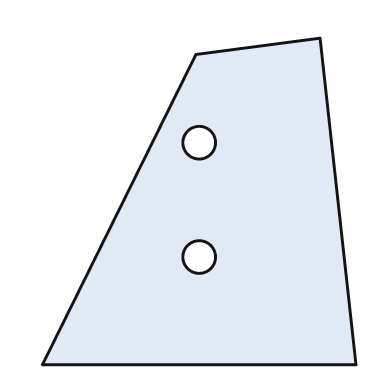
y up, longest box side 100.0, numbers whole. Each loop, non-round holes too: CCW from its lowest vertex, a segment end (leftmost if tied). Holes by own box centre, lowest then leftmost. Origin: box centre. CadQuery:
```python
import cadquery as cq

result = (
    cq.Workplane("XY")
    .moveTo(-48.0, -50.0)
    .lineTo(48.0, -50.0)
    .lineTo(37.0, 50.0)
    .lineTo(-1.0, 45.0)
    .close()
    .moveTo(0.0, -17.0)
    .circle(5.0)
    .moveTo(0.0, 18.0)
    .circle(5.0)
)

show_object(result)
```